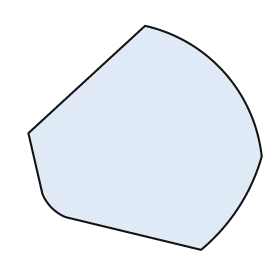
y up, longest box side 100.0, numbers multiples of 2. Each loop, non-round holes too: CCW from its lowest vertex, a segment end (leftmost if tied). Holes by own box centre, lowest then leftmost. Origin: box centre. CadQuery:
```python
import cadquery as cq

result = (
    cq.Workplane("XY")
    .moveTo(24.0, -48.0)
    .threePointArc((40.0, -30.0), (50.0, -8.0))
    .threePointArc((34.0, 28.0), (0.0, 48.0))
    .lineTo(-50.0, 2.0)
    .lineTo(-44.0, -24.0)
    .threePointArc((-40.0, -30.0), (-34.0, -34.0))
    .close()
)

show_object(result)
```